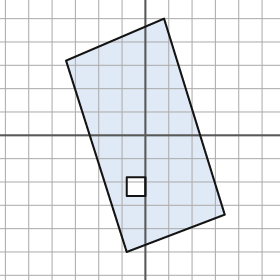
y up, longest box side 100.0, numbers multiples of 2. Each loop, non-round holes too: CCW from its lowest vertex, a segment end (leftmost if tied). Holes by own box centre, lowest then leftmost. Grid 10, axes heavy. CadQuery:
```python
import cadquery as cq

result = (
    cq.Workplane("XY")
    .moveTo(-8.0, -50.0)
    .lineTo(34.0, -34.0)
    .lineTo(8.0, 50.0)
    .lineTo(-34.0, 32.0)
    .close()
    .moveTo(-8.0, -26.0)
    .lineTo(0.0, -26.0)
    .lineTo(0.0, -18.0)
    .lineTo(-8.0, -18.0)
    .close()
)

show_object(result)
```